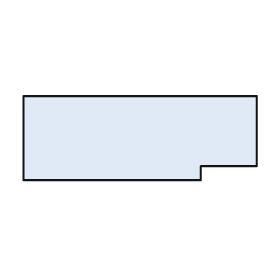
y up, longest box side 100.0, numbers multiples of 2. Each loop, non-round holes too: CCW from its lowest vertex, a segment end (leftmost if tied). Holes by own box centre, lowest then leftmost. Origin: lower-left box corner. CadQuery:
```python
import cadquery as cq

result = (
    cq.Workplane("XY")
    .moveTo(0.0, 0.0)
    .lineTo(76.0, 0.0)
    .lineTo(76.0, 6.0)
    .lineTo(100.0, 6.0)
    .lineTo(100.0, 36.0)
    .lineTo(0.0, 36.0)
    .close()
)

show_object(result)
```